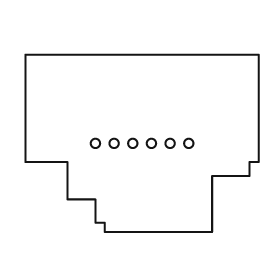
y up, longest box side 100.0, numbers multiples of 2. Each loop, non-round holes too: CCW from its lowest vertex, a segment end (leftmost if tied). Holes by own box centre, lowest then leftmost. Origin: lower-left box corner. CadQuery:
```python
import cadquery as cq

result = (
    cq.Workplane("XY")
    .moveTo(34.0, 0.0)
    .lineTo(80.0, 0.0)
    .lineTo(80.0, 24.0)
    .lineTo(96.0, 24.0)
    .lineTo(96.0, 30.0)
    .lineTo(100.0, 30.0)
    .lineTo(100.0, 76.0)
    .lineTo(0.0, 76.0)
    .lineTo(0.0, 30.0)
    .lineTo(18.0, 30.0)
    .lineTo(18.0, 14.0)
    .lineTo(30.0, 14.0)
    .lineTo(30.0, 4.0)
    .lineTo(34.0, 4.0)
    .close()
    .moveTo(30.0, 38.0)
    .circle(2.0)
    .moveTo(38.0, 38.0)
    .circle(2.0)
    .moveTo(46.0, 38.0)
    .circle(2.0)
    .moveTo(54.0, 38.0)
    .circle(2.0)
    .moveTo(62.0, 38.0)
    .circle(2.0)
    .moveTo(70.0, 38.0)
    .circle(2.0)
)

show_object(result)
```